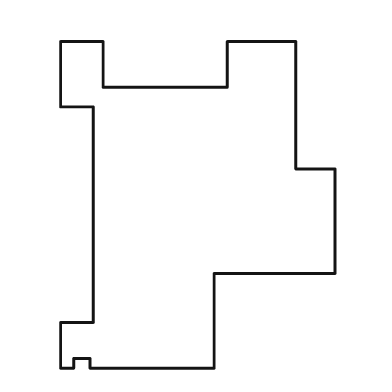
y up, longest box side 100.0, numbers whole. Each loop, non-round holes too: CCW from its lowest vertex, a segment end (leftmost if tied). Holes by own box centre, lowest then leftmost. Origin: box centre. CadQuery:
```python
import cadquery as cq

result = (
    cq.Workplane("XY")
    .moveTo(-42.0, -50.0)
    .lineTo(-38.0, -50.0)
    .lineTo(-38.0, -47.0)
    .lineTo(-33.0, -47.0)
    .lineTo(-33.0, -50.0)
    .lineTo(5.0, -50.0)
    .lineTo(5.0, -21.0)
    .lineTo(42.0, -21.0)
    .lineTo(42.0, 11.0)
    .lineTo(30.0, 11.0)
    .lineTo(30.0, 50.0)
    .lineTo(9.0, 50.0)
    .lineTo(9.0, 36.0)
    .lineTo(-29.0, 36.0)
    .lineTo(-29.0, 50.0)
    .lineTo(-42.0, 50.0)
    .lineTo(-42.0, 30.0)
    .lineTo(-32.0, 30.0)
    .lineTo(-32.0, -36.0)
    .lineTo(-42.0, -36.0)
    .close()
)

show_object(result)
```